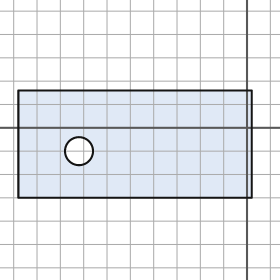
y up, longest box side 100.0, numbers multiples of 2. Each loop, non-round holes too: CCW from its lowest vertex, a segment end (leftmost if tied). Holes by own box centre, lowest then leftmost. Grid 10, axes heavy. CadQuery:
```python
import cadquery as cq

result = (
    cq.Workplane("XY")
    .moveTo(-98.0, -30.0)
    .lineTo(2.0, -30.0)
    .lineTo(2.0, 16.0)
    .lineTo(-98.0, 16.0)
    .close()
    .moveTo(-72.0, -10.0)
    .circle(6.0)
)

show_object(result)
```